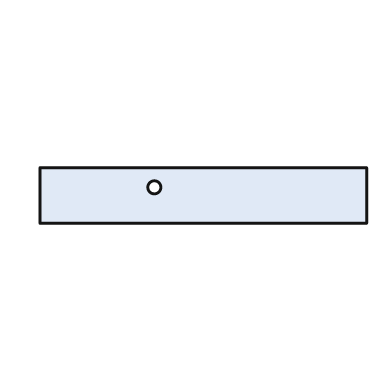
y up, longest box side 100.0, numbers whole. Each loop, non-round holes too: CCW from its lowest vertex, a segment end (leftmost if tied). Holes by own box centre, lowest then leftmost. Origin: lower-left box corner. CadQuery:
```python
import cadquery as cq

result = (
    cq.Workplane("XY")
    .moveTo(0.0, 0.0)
    .lineTo(100.0, 0.0)
    .lineTo(100.0, 17.0)
    .lineTo(0.0, 17.0)
    .close()
    .moveTo(35.0, 11.0)
    .circle(2.0)
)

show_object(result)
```